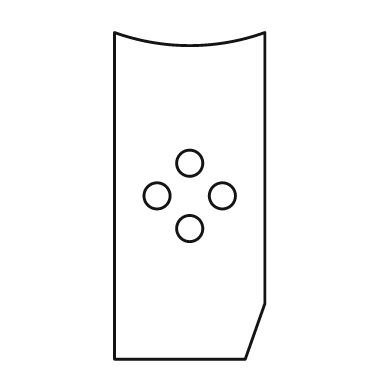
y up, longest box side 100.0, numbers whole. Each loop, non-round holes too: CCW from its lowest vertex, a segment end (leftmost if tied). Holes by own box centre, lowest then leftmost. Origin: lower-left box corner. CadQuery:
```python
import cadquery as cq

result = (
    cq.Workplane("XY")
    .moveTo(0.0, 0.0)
    .lineTo(40.0, 0.0)
    .lineTo(46.0, 17.0)
    .lineTo(46.0, 100.0)
    .threePointArc((23.0, 96.0), (0.0, 100.0))
    .close()
    .moveTo(23.0, 40.0)
    .circle(4.0)
    .moveTo(13.0, 50.0)
    .circle(4.0)
    .moveTo(33.0, 50.0)
    .circle(4.0)
    .moveTo(23.0, 60.0)
    .circle(4.0)
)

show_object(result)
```